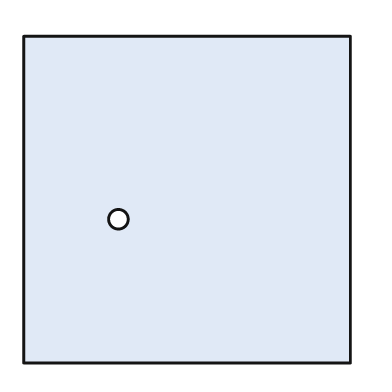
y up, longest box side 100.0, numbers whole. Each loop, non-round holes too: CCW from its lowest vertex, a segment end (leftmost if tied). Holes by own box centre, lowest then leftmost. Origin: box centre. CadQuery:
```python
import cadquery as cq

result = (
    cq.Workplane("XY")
    .moveTo(-50.0, -50.0)
    .lineTo(50.0, -50.0)
    .lineTo(50.0, 50.0)
    .lineTo(-50.0, 50.0)
    .close()
    .moveTo(-21.0, -6.0)
    .circle(3.0)
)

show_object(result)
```